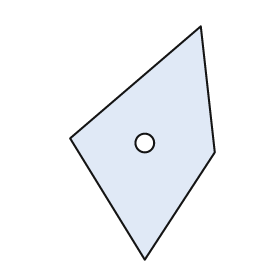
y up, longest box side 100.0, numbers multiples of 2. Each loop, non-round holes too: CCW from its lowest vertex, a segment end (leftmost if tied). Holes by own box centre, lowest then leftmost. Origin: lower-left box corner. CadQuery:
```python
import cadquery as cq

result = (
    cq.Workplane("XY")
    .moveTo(32.0, 0.0)
    .lineTo(62.0, 46.0)
    .lineTo(56.0, 100.0)
    .lineTo(0.0, 52.0)
    .close()
    .moveTo(32.0, 50.0)
    .circle(4.0)
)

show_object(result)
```